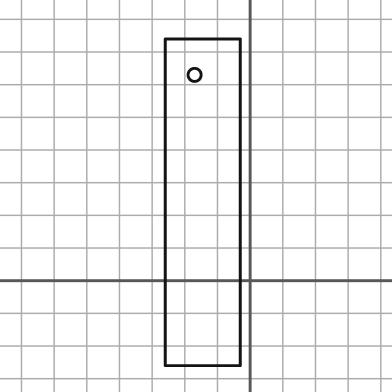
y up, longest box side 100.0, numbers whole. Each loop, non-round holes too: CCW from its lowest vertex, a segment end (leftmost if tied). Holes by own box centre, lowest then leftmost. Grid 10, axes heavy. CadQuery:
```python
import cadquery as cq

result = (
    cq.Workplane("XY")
    .moveTo(-26.0, -26.0)
    .lineTo(-3.0, -26.0)
    .lineTo(-3.0, 74.0)
    .lineTo(-26.0, 74.0)
    .close()
    .moveTo(-17.0, 63.0)
    .circle(2.0)
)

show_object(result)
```